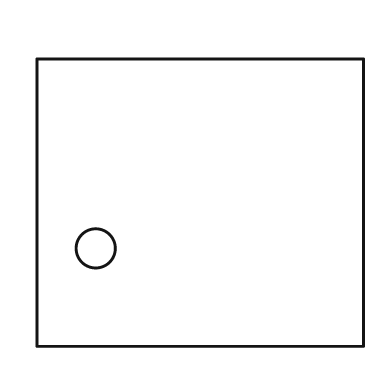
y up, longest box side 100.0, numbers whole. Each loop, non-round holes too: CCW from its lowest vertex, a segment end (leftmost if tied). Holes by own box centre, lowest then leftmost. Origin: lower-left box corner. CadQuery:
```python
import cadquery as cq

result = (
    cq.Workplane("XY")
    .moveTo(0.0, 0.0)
    .lineTo(100.0, 0.0)
    .lineTo(100.0, 88.0)
    .lineTo(0.0, 88.0)
    .close()
    .moveTo(18.0, 30.0)
    .circle(6.0)
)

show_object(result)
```